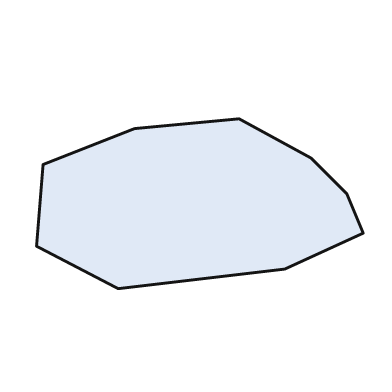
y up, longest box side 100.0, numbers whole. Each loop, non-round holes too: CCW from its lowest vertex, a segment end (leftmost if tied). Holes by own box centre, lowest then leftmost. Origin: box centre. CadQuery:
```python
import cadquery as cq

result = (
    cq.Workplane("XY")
    .moveTo(-25.0, -26.0)
    .lineTo(26.0, -20.0)
    .lineTo(50.0, -9.0)
    .lineTo(45.0, 3.0)
    .lineTo(34.0, 14.0)
    .lineTo(12.0, 26.0)
    .lineTo(-20.0, 23.0)
    .lineTo(-48.0, 12.0)
    .lineTo(-50.0, -13.0)
    .close()
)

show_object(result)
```